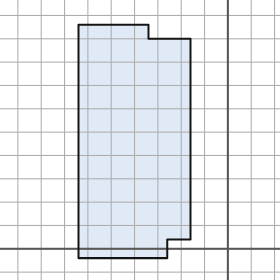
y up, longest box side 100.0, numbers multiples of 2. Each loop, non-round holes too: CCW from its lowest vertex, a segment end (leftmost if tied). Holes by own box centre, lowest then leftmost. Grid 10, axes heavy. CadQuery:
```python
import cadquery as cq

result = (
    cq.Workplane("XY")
    .moveTo(-64.0, -4.0)
    .lineTo(-26.0, -4.0)
    .lineTo(-26.0, 4.0)
    .lineTo(-16.0, 4.0)
    .lineTo(-16.0, 90.0)
    .lineTo(-34.0, 90.0)
    .lineTo(-34.0, 96.0)
    .lineTo(-64.0, 96.0)
    .close()
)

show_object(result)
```